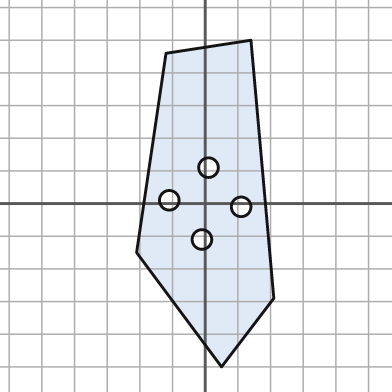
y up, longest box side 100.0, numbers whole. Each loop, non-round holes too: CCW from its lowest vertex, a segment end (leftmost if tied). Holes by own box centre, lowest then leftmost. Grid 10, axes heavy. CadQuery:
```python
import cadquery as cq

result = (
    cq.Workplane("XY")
    .moveTo(5.0, -50.0)
    .lineTo(21.0, -29.0)
    .lineTo(14.0, 50.0)
    .lineTo(-12.0, 46.0)
    .lineTo(-21.0, -15.0)
    .close()
    .moveTo(-1.0, -11.0)
    .circle(3.0)
    .moveTo(11.0, -1.0)
    .circle(3.0)
    .moveTo(-11.0, 1.0)
    .circle(3.0)
    .moveTo(1.0, 11.0)
    .circle(3.0)
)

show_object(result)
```